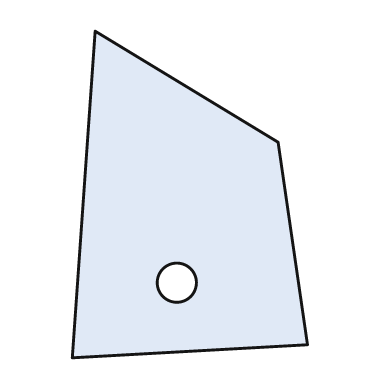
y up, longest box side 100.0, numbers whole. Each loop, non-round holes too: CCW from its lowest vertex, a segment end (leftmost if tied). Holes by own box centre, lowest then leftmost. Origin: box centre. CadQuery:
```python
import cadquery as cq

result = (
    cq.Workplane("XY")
    .moveTo(-36.0, -50.0)
    .lineTo(36.0, -46.0)
    .lineTo(27.0, 16.0)
    .lineTo(-29.0, 50.0)
    .close()
    .moveTo(-4.0, -27.0)
    .circle(6.0)
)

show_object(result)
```